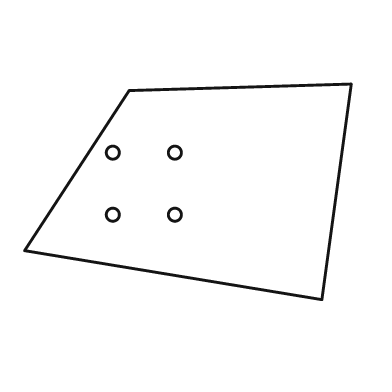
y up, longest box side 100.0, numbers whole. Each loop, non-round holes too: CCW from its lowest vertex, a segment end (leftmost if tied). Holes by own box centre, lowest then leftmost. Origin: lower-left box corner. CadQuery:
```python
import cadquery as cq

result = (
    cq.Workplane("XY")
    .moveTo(91.0, 0.0)
    .lineTo(100.0, 66.0)
    .lineTo(32.0, 64.0)
    .lineTo(0.0, 15.0)
    .close()
    .moveTo(27.0, 26.0)
    .circle(2.0)
    .moveTo(46.0, 26.0)
    .circle(2.0)
    .moveTo(27.0, 45.0)
    .circle(2.0)
    .moveTo(46.0, 45.0)
    .circle(2.0)
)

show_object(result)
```